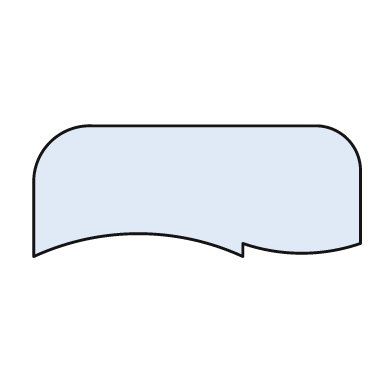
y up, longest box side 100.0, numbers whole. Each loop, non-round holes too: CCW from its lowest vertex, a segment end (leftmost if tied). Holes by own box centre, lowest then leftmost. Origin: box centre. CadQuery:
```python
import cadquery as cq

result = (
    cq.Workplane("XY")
    .moveTo(-50.0, -20.0)
    .threePointArc((-18.0, -13.0), (14.0, -20.0))
    .lineTo(14.0, -16.0)
    .threePointArc((32.0, -19.0), (50.0, -16.0))
    .lineTo(50.0, 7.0)
    .threePointArc((46.0, 16.0), (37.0, 20.0))
    .lineTo(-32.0, 20.0)
    .threePointArc((-45.0, 15.0), (-50.0, 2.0))
    .close()
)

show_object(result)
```